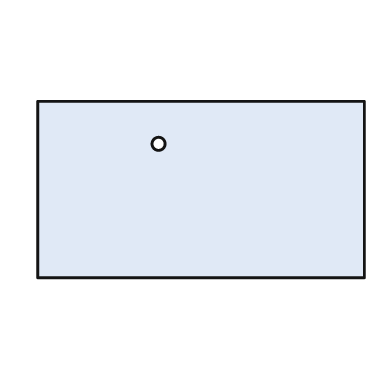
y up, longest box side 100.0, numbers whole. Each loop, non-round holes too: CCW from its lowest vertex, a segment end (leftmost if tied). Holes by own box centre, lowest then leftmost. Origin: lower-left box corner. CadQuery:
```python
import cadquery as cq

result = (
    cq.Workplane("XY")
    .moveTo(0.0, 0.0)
    .lineTo(100.0, 0.0)
    .lineTo(100.0, 54.0)
    .lineTo(0.0, 54.0)
    .close()
    .moveTo(37.0, 41.0)
    .circle(2.0)
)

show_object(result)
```